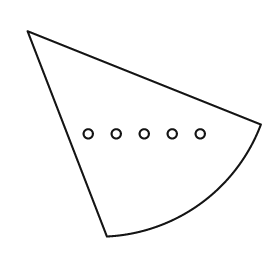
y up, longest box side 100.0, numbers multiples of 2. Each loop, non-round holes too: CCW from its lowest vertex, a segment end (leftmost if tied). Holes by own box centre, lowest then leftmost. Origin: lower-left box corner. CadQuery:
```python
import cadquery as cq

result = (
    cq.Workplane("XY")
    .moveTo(34.0, 0.0)
    .threePointArc((74.0, 14.0), (100.0, 48.0))
    .lineTo(0.0, 88.0)
    .close()
    .moveTo(26.0, 44.0)
    .circle(2.0)
    .moveTo(38.0, 44.0)
    .circle(2.0)
    .moveTo(50.0, 44.0)
    .circle(2.0)
    .moveTo(62.0, 44.0)
    .circle(2.0)
    .moveTo(74.0, 44.0)
    .circle(2.0)
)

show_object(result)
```